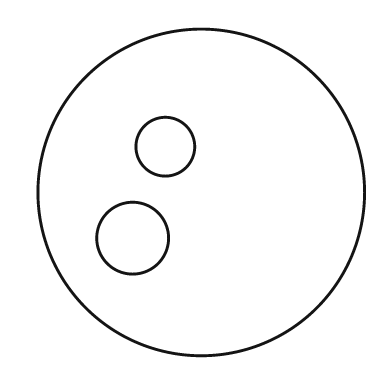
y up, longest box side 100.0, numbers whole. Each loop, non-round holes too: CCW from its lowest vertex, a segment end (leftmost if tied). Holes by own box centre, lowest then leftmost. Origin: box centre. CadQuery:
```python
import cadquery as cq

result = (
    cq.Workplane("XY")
    .moveTo(0.0, 0.0)
    .circle(50.0)
    .moveTo(-21.0, -14.0)
    .circle(11.0)
    .moveTo(-11.0, 14.0)
    .circle(9.0)
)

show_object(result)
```